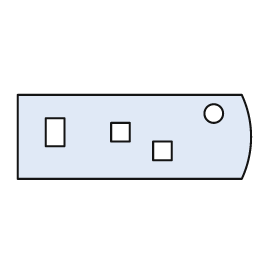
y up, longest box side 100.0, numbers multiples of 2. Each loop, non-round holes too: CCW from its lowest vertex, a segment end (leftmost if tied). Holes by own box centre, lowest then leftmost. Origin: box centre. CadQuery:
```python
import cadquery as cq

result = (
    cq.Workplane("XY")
    .moveTo(-50.0, -18.0)
    .lineTo(46.0, -18.0)
    .threePointArc((50.0, 0.0), (46.0, 18.0))
    .lineTo(-50.0, 18.0)
    .close()
    .moveTo(8.0, -10.0)
    .lineTo(16.0, -10.0)
    .lineTo(16.0, -2.0)
    .lineTo(8.0, -2.0)
    .close()
    .moveTo(-38.0, -4.0)
    .lineTo(-30.0, -4.0)
    .lineTo(-30.0, 8.0)
    .lineTo(-38.0, 8.0)
    .close()
    .moveTo(-10.0, -2.0)
    .lineTo(-2.0, -2.0)
    .lineTo(-2.0, 6.0)
    .lineTo(-10.0, 6.0)
    .close()
    .moveTo(34.0, 10.0)
    .circle(4.0)
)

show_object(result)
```